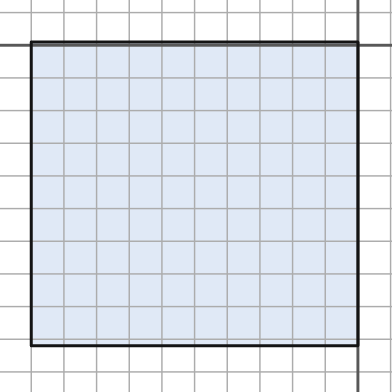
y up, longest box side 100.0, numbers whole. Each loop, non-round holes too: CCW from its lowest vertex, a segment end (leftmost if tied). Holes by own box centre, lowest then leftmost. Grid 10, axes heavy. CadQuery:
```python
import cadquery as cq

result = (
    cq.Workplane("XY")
    .moveTo(-100.0, -92.0)
    .lineTo(0.0, -92.0)
    .lineTo(0.0, 1.0)
    .lineTo(-100.0, 1.0)
    .close()
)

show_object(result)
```